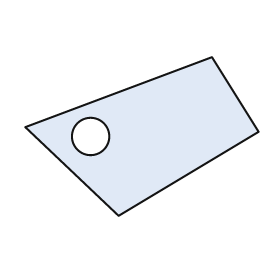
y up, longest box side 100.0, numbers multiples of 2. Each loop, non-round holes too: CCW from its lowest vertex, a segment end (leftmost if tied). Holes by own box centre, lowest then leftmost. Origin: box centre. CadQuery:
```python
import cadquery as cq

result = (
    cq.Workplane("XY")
    .moveTo(-10.0, -34.0)
    .lineTo(50.0, 2.0)
    .lineTo(30.0, 34.0)
    .lineTo(-50.0, 4.0)
    .close()
    .moveTo(-22.0, 0.0)
    .circle(8.0)
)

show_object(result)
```